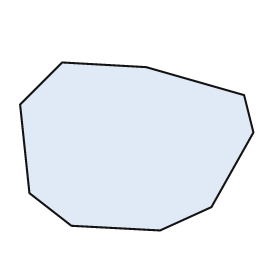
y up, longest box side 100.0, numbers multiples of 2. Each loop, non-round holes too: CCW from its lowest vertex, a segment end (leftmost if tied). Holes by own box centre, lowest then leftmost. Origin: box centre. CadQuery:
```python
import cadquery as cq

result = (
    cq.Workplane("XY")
    .moveTo(10.0, -36.0)
    .lineTo(32.0, -26.0)
    .lineTo(50.0, 6.0)
    .lineTo(46.0, 22.0)
    .lineTo(4.0, 34.0)
    .lineTo(-32.0, 36.0)
    .lineTo(-50.0, 18.0)
    .lineTo(-46.0, -20.0)
    .lineTo(-28.0, -34.0)
    .close()
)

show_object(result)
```